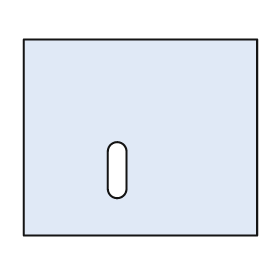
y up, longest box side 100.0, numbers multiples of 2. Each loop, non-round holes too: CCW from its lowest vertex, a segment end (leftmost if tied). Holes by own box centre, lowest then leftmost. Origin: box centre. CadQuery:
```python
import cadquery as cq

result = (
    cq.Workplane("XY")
    .moveTo(-50.0, -42.0)
    .lineTo(50.0, -42.0)
    .lineTo(50.0, 42.0)
    .lineTo(-50.0, 42.0)
    .close()
    .moveTo(-14.0, -22.0)
    .threePointArc((-10.0, -26.0), (-6.0, -22.0))
    .lineTo(-6.0, -6.0)
    .threePointArc((-10.0, -2.0), (-14.0, -6.0))
    .close()
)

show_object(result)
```